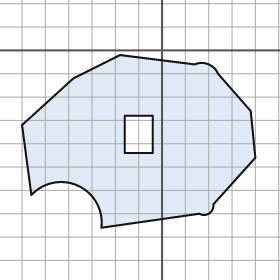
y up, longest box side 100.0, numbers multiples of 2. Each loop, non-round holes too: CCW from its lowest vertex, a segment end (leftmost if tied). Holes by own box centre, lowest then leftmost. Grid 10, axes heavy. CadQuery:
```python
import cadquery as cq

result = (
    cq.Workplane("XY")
    .moveTo(-26.0, -76.0)
    .lineTo(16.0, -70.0)
    .threePointArc((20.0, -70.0), (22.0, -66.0))
    .lineTo(40.0, -46.0)
    .lineTo(38.0, -26.0)
    .lineTo(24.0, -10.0)
    .threePointArc((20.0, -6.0), (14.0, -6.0))
    .lineTo(-18.0, -2.0)
    .lineTo(-38.0, -12.0)
    .lineTo(-60.0, -32.0)
    .lineTo(-56.0, -62.0)
    .threePointArc((-36.0, -58.0), (-26.0, -76.0))
    .close()
    .moveTo(-16.0, -44.0)
    .lineTo(-4.0, -44.0)
    .lineTo(-4.0, -28.0)
    .lineTo(-16.0, -28.0)
    .close()
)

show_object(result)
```